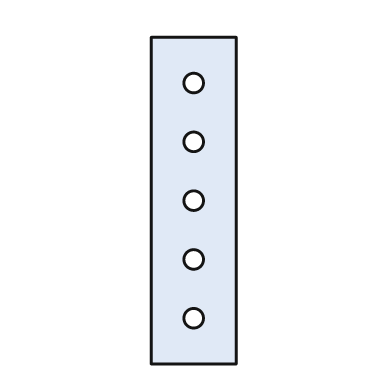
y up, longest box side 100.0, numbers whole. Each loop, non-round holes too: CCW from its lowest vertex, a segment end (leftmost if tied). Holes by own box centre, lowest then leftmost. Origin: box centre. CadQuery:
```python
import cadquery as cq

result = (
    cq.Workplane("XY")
    .moveTo(-13.0, -50.0)
    .lineTo(13.0, -50.0)
    .lineTo(13.0, 50.0)
    .lineTo(-13.0, 50.0)
    .close()
    .moveTo(0.0, -36.0)
    .circle(3.0)
    .moveTo(0.0, -18.0)
    .circle(3.0)
    .moveTo(0.0, 0.0)
    .circle(3.0)
    .moveTo(0.0, 18.0)
    .circle(3.0)
    .moveTo(0.0, 36.0)
    .circle(3.0)
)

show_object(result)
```